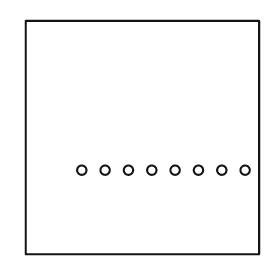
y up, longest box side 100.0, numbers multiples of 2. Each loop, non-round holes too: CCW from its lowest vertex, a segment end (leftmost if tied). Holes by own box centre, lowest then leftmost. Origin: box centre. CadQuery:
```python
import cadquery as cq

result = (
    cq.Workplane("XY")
    .moveTo(-50.0, -50.0)
    .lineTo(50.0, -50.0)
    .lineTo(50.0, 50.0)
    .lineTo(-50.0, 50.0)
    .close()
    .moveTo(-26.0, -14.0)
    .circle(2.0)
    .moveTo(-16.0, -14.0)
    .circle(2.0)
    .moveTo(-6.0, -14.0)
    .circle(2.0)
    .moveTo(4.0, -14.0)
    .circle(2.0)
    .moveTo(14.0, -14.0)
    .circle(2.0)
    .moveTo(24.0, -14.0)
    .circle(2.0)
    .moveTo(34.0, -14.0)
    .circle(2.0)
    .moveTo(44.0, -14.0)
    .circle(2.0)
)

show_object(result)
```